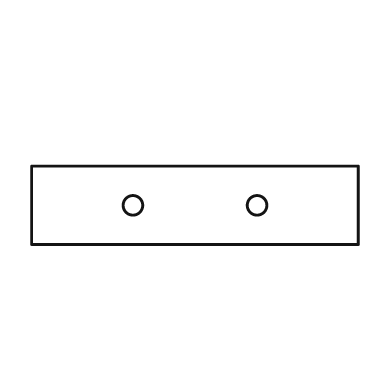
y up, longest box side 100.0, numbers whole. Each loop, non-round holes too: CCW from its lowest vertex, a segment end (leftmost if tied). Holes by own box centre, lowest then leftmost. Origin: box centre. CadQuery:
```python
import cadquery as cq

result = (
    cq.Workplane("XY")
    .moveTo(-50.0, -12.0)
    .lineTo(50.0, -12.0)
    .lineTo(50.0, 12.0)
    .lineTo(-50.0, 12.0)
    .close()
    .moveTo(-19.0, 0.0)
    .circle(3.0)
    .moveTo(19.0, 0.0)
    .circle(3.0)
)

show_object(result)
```